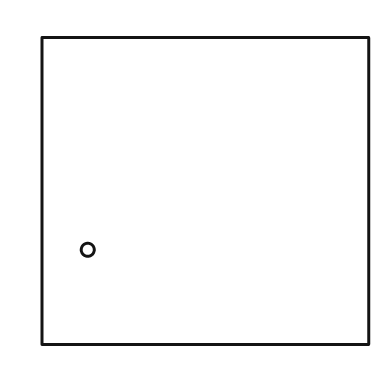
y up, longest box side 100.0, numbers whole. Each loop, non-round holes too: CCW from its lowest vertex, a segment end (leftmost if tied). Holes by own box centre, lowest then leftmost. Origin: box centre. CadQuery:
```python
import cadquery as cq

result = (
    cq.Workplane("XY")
    .moveTo(-50.0, -47.0)
    .lineTo(50.0, -47.0)
    .lineTo(50.0, 47.0)
    .lineTo(-50.0, 47.0)
    .close()
    .moveTo(-36.0, -18.0)
    .circle(2.0)
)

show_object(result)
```